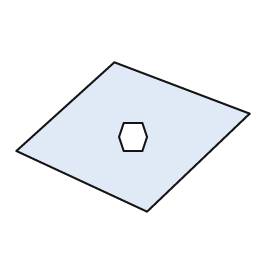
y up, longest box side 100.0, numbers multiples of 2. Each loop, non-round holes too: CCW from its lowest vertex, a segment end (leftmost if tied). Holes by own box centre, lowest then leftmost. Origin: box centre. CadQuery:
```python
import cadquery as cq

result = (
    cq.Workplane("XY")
    .moveTo(6.0, -32.0)
    .lineTo(50.0, 10.0)
    .lineTo(-8.0, 32.0)
    .lineTo(-50.0, -6.0)
    .close()
    .moveTo(-4.0, -6.0)
    .lineTo(4.0, -6.0)
    .lineTo(6.0, 0.0)
    .lineTo(4.0, 6.0)
    .lineTo(-4.0, 6.0)
    .lineTo(-6.0, 0.0)
    .close()
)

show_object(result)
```